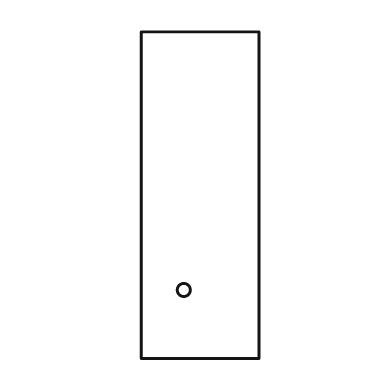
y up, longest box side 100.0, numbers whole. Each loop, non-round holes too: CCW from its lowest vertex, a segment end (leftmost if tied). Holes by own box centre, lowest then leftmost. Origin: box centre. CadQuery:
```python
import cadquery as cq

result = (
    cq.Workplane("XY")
    .moveTo(-18.0, -50.0)
    .lineTo(18.0, -50.0)
    .lineTo(18.0, 50.0)
    .lineTo(-18.0, 50.0)
    .close()
    .moveTo(-5.0, -29.0)
    .circle(2.0)
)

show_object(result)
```